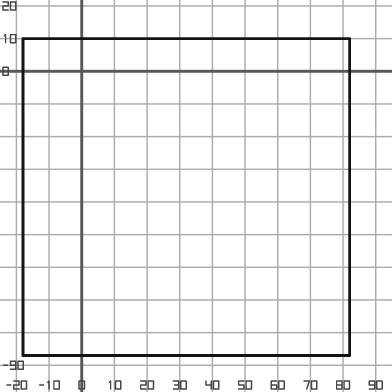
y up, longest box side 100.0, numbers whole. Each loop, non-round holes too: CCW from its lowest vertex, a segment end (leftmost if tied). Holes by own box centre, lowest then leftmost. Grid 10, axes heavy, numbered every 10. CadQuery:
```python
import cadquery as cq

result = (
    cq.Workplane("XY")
    .moveTo(-18.0, -87.0)
    .lineTo(82.0, -87.0)
    .lineTo(82.0, 10.0)
    .lineTo(-18.0, 10.0)
    .close()
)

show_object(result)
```